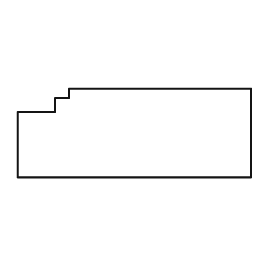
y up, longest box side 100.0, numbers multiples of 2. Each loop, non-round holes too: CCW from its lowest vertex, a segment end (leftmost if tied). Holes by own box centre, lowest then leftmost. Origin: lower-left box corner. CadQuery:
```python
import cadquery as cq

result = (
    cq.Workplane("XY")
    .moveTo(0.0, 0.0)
    .lineTo(100.0, 0.0)
    .lineTo(100.0, 38.0)
    .lineTo(22.0, 38.0)
    .lineTo(22.0, 34.0)
    .lineTo(16.0, 34.0)
    .lineTo(16.0, 28.0)
    .lineTo(0.0, 28.0)
    .close()
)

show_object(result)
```